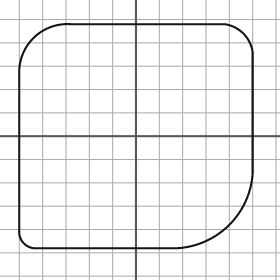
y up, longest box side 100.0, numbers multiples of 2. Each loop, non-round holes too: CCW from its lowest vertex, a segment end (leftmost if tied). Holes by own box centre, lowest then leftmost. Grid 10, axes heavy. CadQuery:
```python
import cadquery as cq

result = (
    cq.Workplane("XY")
    .moveTo(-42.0, -48.0)
    .lineTo(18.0, -48.0)
    .threePointArc((40.0, -38.0), (50.0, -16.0))
    .lineTo(50.0, 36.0)
    .threePointArc((46.0, 44.0), (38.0, 48.0))
    .lineTo(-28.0, 48.0)
    .threePointArc((-44.0, 42.0), (-50.0, 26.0))
    .lineTo(-50.0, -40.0)
    .threePointArc((-48.0, -46.0), (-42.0, -48.0))
    .close()
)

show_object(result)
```